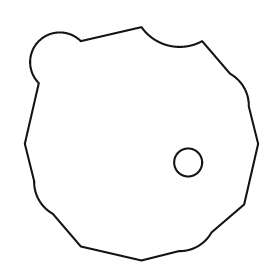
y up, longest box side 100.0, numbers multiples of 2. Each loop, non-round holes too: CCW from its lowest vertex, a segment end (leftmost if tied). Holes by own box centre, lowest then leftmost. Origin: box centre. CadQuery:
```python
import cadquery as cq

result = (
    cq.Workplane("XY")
    .moveTo(0.0, -50.0)
    .lineTo(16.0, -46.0)
    .threePointArc((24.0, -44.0), (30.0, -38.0))
    .lineTo(44.0, -26.0)
    .lineTo(50.0, 0.0)
    .lineTo(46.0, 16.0)
    .threePointArc((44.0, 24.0), (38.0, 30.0))
    .lineTo(26.0, 44.0)
    .threePointArc((12.0, 42.0), (0.0, 50.0))
    .lineTo(-26.0, 44.0)
    .threePointArc((-44.0, 44.0), (-44.0, 26.0))
    .lineTo(-50.0, 0.0)
    .lineTo(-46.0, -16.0)
    .threePointArc((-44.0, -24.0), (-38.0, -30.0))
    .lineTo(-26.0, -44.0)
    .close()
    .moveTo(20.0, -8.0)
    .circle(6.0)
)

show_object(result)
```